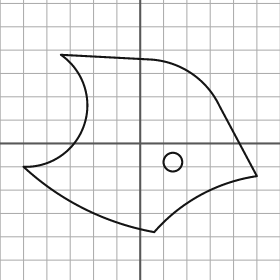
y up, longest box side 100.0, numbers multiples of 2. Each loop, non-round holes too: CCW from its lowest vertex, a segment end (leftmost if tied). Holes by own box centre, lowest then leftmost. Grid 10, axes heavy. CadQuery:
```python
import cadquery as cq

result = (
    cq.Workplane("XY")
    .moveTo(6.0, -38.0)
    .threePointArc((26.0, -22.0), (50.0, -14.0))
    .lineTo(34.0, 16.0)
    .threePointArc((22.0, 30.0), (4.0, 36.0))
    .lineTo(-34.0, 38.0)
    .threePointArc((-24.0, 8.0), (-50.0, -10.0))
    .threePointArc((-24.0, -28.0), (6.0, -38.0))
    .close()
    .moveTo(14.0, -8.0)
    .circle(4.0)
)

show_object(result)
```